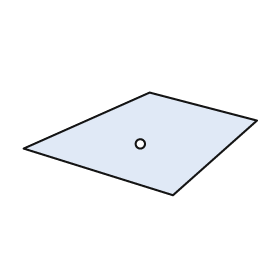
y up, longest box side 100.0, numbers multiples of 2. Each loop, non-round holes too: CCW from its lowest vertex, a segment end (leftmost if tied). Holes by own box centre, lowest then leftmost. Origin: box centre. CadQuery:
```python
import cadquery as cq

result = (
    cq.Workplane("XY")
    .moveTo(14.0, -22.0)
    .lineTo(50.0, 10.0)
    .lineTo(4.0, 22.0)
    .lineTo(-50.0, -2.0)
    .close()
    .moveTo(0.0, 0.0)
    .circle(2.0)
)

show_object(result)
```